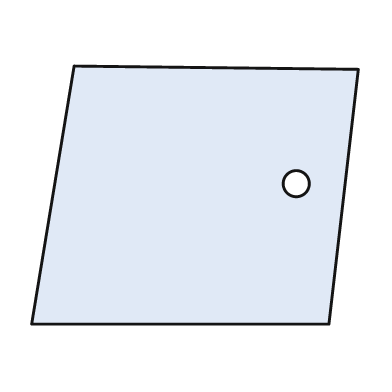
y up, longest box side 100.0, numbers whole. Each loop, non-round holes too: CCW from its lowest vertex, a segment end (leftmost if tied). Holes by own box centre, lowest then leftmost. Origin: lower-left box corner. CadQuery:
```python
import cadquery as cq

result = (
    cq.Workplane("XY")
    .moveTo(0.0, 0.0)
    .lineTo(91.0, 0.0)
    .lineTo(100.0, 78.0)
    .lineTo(13.0, 79.0)
    .close()
    .moveTo(81.0, 43.0)
    .circle(4.0)
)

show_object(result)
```